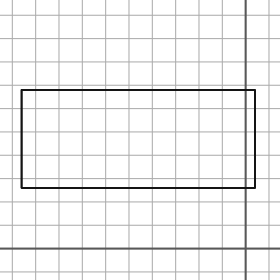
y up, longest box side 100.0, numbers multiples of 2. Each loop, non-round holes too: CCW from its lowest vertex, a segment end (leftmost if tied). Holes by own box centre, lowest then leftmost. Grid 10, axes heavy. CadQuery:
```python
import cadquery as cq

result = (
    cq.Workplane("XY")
    .moveTo(-96.0, 26.0)
    .lineTo(4.0, 26.0)
    .lineTo(4.0, 68.0)
    .lineTo(-96.0, 68.0)
    .close()
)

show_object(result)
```